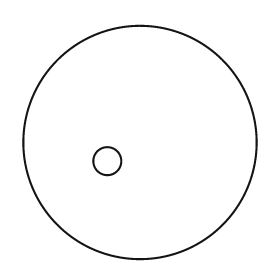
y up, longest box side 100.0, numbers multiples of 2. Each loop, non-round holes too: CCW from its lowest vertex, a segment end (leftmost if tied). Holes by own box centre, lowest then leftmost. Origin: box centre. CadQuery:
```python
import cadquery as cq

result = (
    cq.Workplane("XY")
    .moveTo(0.0, 0.0)
    .circle(50.0)
    .moveTo(-14.0, -8.0)
    .circle(6.0)
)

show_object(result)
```